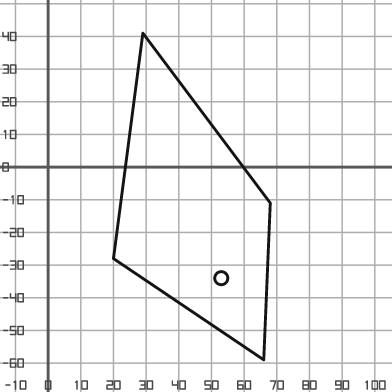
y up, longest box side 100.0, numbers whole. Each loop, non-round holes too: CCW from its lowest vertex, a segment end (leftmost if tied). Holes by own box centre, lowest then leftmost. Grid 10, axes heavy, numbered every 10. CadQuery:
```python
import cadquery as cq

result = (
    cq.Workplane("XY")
    .moveTo(66.0, -59.0)
    .lineTo(68.0, -11.0)
    .lineTo(29.0, 41.0)
    .lineTo(20.0, -28.0)
    .close()
    .moveTo(53.0, -34.0)
    .circle(2.0)
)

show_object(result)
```